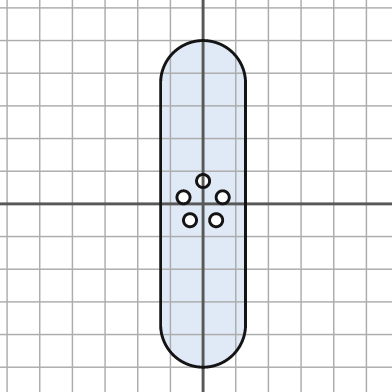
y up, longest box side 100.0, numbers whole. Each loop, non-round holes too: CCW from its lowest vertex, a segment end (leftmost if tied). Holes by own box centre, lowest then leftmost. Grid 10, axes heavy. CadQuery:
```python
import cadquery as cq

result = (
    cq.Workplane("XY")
    .moveTo(-13.0, -37.0)
    .threePointArc((0.0, -50.0), (13.0, -37.0))
    .lineTo(13.0, 37.0)
    .threePointArc((0.0, 50.0), (-13.0, 37.0))
    .close()
    .moveTo(-4.0, -5.0)
    .circle(2.0)
    .moveTo(4.0, -5.0)
    .circle(2.0)
    .moveTo(-6.0, 2.0)
    .circle(2.0)
    .moveTo(6.0, 2.0)
    .circle(2.0)
    .moveTo(0.0, 7.0)
    .circle(2.0)
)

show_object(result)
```